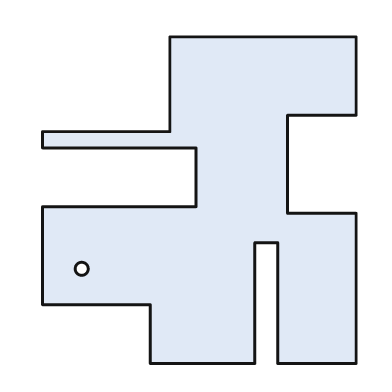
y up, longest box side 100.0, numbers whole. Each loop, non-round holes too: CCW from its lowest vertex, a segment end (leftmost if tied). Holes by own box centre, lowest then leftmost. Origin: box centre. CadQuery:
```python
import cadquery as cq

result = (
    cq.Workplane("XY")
    .moveTo(-15.0, -50.0)
    .lineTo(17.0, -50.0)
    .lineTo(17.0, -13.0)
    .lineTo(24.0, -13.0)
    .lineTo(24.0, -50.0)
    .lineTo(48.0, -50.0)
    .lineTo(48.0, -4.0)
    .lineTo(27.0, -4.0)
    .lineTo(27.0, 26.0)
    .lineTo(48.0, 26.0)
    .lineTo(48.0, 50.0)
    .lineTo(-9.0, 50.0)
    .lineTo(-9.0, 21.0)
    .lineTo(-48.0, 21.0)
    .lineTo(-48.0, 16.0)
    .lineTo(-1.0, 16.0)
    .lineTo(-1.0, -2.0)
    .lineTo(-48.0, -2.0)
    .lineTo(-48.0, -32.0)
    .lineTo(-15.0, -32.0)
    .close()
    .moveTo(-36.0, -21.0)
    .circle(2.0)
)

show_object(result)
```